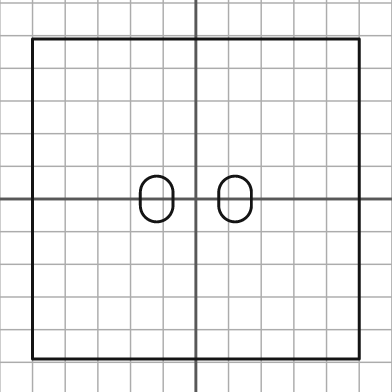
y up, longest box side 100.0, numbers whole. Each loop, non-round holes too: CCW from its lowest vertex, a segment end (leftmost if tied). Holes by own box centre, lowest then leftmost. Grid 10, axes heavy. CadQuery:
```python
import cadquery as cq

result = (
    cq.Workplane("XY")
    .moveTo(-50.0, -49.0)
    .lineTo(50.0, -49.0)
    .lineTo(50.0, 49.0)
    .lineTo(-50.0, 49.0)
    .close()
    .moveTo(-17.0, -2.0)
    .threePointArc((-12.0, -7.0), (-7.0, -2.0))
    .lineTo(-7.0, 2.0)
    .threePointArc((-12.0, 7.0), (-17.0, 2.0))
    .close()
    .moveTo(7.0, -2.0)
    .threePointArc((12.0, -7.0), (17.0, -2.0))
    .lineTo(17.0, 2.0)
    .threePointArc((12.0, 7.0), (7.0, 2.0))
    .close()
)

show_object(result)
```